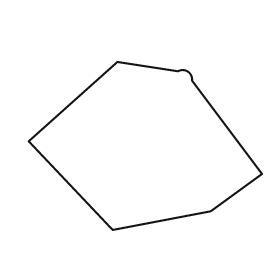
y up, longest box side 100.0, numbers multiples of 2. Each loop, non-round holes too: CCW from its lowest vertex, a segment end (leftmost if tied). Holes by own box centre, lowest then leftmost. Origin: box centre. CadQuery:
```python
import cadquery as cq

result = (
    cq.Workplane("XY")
    .moveTo(-14.0, -36.0)
    .lineTo(28.0, -28.0)
    .lineTo(50.0, -12.0)
    .lineTo(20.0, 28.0)
    .threePointArc((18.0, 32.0), (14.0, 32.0))
    .lineTo(-12.0, 36.0)
    .lineTo(-50.0, 2.0)
    .close()
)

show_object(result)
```